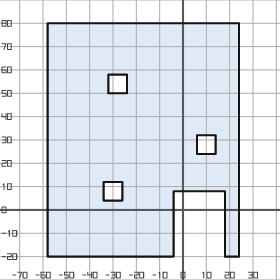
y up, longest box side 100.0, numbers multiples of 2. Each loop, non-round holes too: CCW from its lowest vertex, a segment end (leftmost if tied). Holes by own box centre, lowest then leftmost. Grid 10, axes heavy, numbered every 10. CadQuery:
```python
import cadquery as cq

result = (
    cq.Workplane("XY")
    .moveTo(-58.0, -20.0)
    .lineTo(-4.0, -20.0)
    .lineTo(-4.0, 8.0)
    .lineTo(18.0, 8.0)
    .lineTo(18.0, -20.0)
    .lineTo(24.0, -20.0)
    .lineTo(24.0, 80.0)
    .lineTo(-58.0, 80.0)
    .close()
    .moveTo(-34.0, 4.0)
    .lineTo(-26.0, 4.0)
    .lineTo(-26.0, 12.0)
    .lineTo(-34.0, 12.0)
    .close()
    .moveTo(6.0, 24.0)
    .lineTo(14.0, 24.0)
    .lineTo(14.0, 32.0)
    .lineTo(6.0, 32.0)
    .close()
    .moveTo(-32.0, 50.0)
    .lineTo(-24.0, 50.0)
    .lineTo(-24.0, 58.0)
    .lineTo(-32.0, 58.0)
    .close()
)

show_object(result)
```